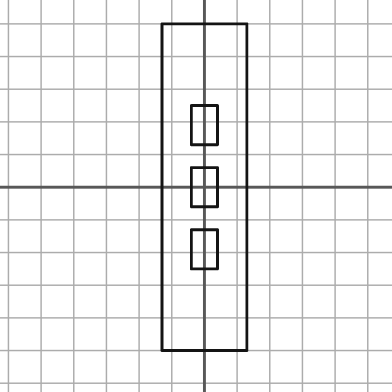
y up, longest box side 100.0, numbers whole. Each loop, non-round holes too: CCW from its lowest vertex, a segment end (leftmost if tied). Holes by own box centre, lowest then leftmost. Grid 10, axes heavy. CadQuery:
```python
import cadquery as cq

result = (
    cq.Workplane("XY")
    .moveTo(-13.0, -50.0)
    .lineTo(13.0, -50.0)
    .lineTo(13.0, 50.0)
    .lineTo(-13.0, 50.0)
    .close()
    .moveTo(-4.0, -25.0)
    .lineTo(4.0, -25.0)
    .lineTo(4.0, -13.0)
    .lineTo(-4.0, -13.0)
    .close()
    .moveTo(-4.0, -6.0)
    .lineTo(4.0, -6.0)
    .lineTo(4.0, 6.0)
    .lineTo(-4.0, 6.0)
    .close()
    .moveTo(-4.0, 13.0)
    .lineTo(4.0, 13.0)
    .lineTo(4.0, 25.0)
    .lineTo(-4.0, 25.0)
    .close()
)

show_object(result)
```